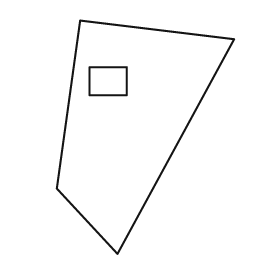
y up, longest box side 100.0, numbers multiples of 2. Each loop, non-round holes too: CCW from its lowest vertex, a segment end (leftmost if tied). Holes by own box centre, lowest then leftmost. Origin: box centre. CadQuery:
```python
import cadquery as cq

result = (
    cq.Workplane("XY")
    .moveTo(-12.0, -50.0)
    .lineTo(38.0, 42.0)
    .lineTo(-28.0, 50.0)
    .lineTo(-38.0, -22.0)
    .close()
    .moveTo(-24.0, 18.0)
    .lineTo(-8.0, 18.0)
    .lineTo(-8.0, 30.0)
    .lineTo(-24.0, 30.0)
    .close()
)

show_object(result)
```